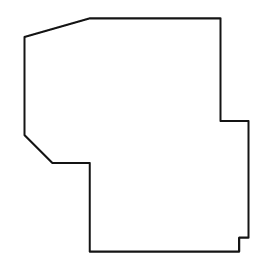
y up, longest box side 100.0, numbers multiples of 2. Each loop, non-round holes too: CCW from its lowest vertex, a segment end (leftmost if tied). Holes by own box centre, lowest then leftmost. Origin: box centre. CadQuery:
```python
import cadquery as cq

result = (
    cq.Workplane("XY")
    .moveTo(-20.0, -50.0)
    .lineTo(44.0, -50.0)
    .lineTo(44.0, -44.0)
    .lineTo(48.0, -44.0)
    .lineTo(48.0, 6.0)
    .lineTo(36.0, 6.0)
    .lineTo(36.0, 50.0)
    .lineTo(-20.0, 50.0)
    .lineTo(-48.0, 42.0)
    .lineTo(-48.0, 0.0)
    .lineTo(-36.0, -12.0)
    .lineTo(-20.0, -12.0)
    .close()
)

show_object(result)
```